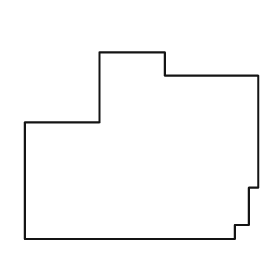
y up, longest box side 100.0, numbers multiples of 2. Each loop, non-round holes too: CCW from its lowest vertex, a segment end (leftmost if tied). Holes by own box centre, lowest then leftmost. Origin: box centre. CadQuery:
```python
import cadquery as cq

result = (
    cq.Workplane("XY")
    .moveTo(-50.0, -40.0)
    .lineTo(40.0, -40.0)
    .lineTo(40.0, -34.0)
    .lineTo(46.0, -34.0)
    .lineTo(46.0, -18.0)
    .lineTo(50.0, -18.0)
    .lineTo(50.0, 30.0)
    .lineTo(10.0, 30.0)
    .lineTo(10.0, 40.0)
    .lineTo(-18.0, 40.0)
    .lineTo(-18.0, 10.0)
    .lineTo(-50.0, 10.0)
    .close()
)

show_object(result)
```